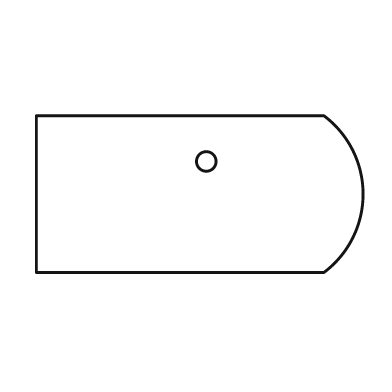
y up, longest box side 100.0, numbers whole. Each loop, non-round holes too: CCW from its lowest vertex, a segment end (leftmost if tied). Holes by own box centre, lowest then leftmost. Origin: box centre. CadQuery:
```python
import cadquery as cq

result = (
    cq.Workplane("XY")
    .moveTo(-50.0, -24.0)
    .lineTo(38.0, -24.0)
    .threePointArc((50.0, 0.0), (38.0, 24.0))
    .lineTo(-50.0, 24.0)
    .close()
    .moveTo(2.0, 10.0)
    .circle(3.0)
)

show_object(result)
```